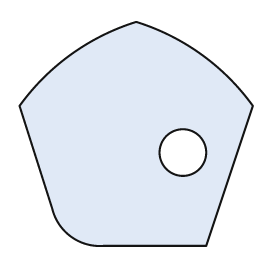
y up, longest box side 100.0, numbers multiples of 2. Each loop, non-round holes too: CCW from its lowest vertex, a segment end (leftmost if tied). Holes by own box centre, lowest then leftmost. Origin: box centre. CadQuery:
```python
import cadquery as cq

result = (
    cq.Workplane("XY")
    .moveTo(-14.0, -48.0)
    .lineTo(30.0, -48.0)
    .lineTo(50.0, 12.0)
    .threePointArc((28.0, 34.0), (0.0, 48.0))
    .threePointArc((-28.0, 34.0), (-50.0, 12.0))
    .lineTo(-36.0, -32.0)
    .threePointArc((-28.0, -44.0), (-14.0, -48.0))
    .close()
    .moveTo(20.0, -8.0)
    .circle(10.0)
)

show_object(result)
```